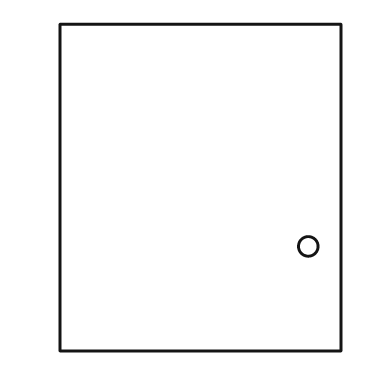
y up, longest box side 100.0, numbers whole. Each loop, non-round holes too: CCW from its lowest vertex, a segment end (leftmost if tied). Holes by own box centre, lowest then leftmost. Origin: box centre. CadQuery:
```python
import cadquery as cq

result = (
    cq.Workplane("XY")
    .moveTo(-43.0, -50.0)
    .lineTo(43.0, -50.0)
    .lineTo(43.0, 50.0)
    .lineTo(-43.0, 50.0)
    .close()
    .moveTo(33.0, -18.0)
    .circle(3.0)
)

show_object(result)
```